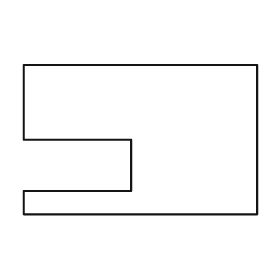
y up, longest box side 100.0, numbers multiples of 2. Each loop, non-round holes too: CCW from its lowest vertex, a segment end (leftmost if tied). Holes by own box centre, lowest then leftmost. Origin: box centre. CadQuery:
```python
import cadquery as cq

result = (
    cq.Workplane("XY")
    .moveTo(-50.0, -32.0)
    .lineTo(50.0, -32.0)
    .lineTo(50.0, 32.0)
    .lineTo(-50.0, 32.0)
    .lineTo(-50.0, 0.0)
    .lineTo(-4.0, 0.0)
    .lineTo(-4.0, -22.0)
    .lineTo(-50.0, -22.0)
    .close()
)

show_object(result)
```